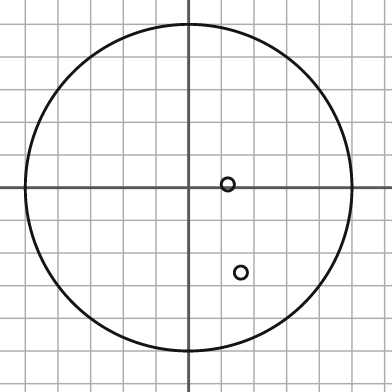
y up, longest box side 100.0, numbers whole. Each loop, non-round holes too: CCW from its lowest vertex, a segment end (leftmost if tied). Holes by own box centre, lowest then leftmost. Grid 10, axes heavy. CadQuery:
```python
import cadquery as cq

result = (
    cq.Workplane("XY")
    .moveTo(0.0, 0.0)
    .circle(50.0)
    .moveTo(16.0, -26.0)
    .circle(2.0)
    .moveTo(12.0, 1.0)
    .circle(2.0)
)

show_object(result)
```